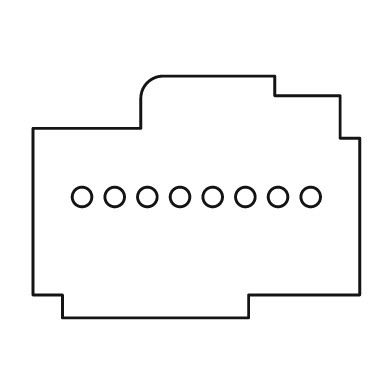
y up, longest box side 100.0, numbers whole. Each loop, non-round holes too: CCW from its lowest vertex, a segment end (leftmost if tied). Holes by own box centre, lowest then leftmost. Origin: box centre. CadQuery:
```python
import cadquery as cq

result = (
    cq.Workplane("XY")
    .moveTo(-41.0, -37.0)
    .lineTo(16.0, -37.0)
    .lineTo(16.0, -30.0)
    .lineTo(50.0, -30.0)
    .lineTo(50.0, 18.0)
    .lineTo(44.0, 18.0)
    .lineTo(44.0, 31.0)
    .lineTo(24.0, 31.0)
    .lineTo(24.0, 37.0)
    .lineTo(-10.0, 37.0)
    .threePointArc((-15.0, 35.0), (-17.0, 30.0))
    .lineTo(-17.0, 21.0)
    .lineTo(-50.0, 21.0)
    .lineTo(-50.0, -30.0)
    .lineTo(-41.0, -30.0)
    .close()
    .moveTo(-35.0, 0.0)
    .circle(3.0)
    .moveTo(-25.0, 0.0)
    .circle(3.0)
    .moveTo(-15.0, 0.0)
    .circle(3.0)
    .moveTo(-5.0, 0.0)
    .circle(3.0)
    .moveTo(5.0, 0.0)
    .circle(3.0)
    .moveTo(15.0, 0.0)
    .circle(3.0)
    .moveTo(25.0, 0.0)
    .circle(3.0)
    .moveTo(35.0, 0.0)
    .circle(3.0)
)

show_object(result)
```